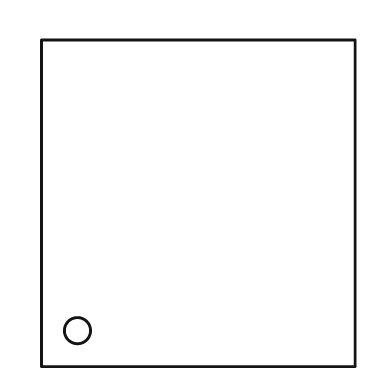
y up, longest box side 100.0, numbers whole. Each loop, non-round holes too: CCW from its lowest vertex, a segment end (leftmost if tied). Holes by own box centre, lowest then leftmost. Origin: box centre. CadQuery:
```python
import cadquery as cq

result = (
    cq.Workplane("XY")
    .moveTo(-48.0, -50.0)
    .lineTo(48.0, -50.0)
    .lineTo(48.0, 50.0)
    .lineTo(-48.0, 50.0)
    .close()
    .moveTo(-37.0, -39.0)
    .circle(4.0)
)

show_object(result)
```